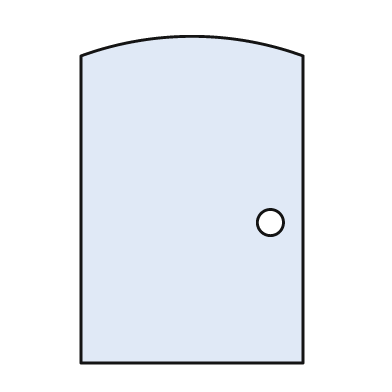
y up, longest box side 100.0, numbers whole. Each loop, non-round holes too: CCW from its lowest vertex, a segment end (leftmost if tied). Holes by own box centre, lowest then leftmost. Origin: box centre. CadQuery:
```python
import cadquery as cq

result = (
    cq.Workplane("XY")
    .moveTo(-34.0, -50.0)
    .lineTo(34.0, -50.0)
    .lineTo(34.0, 44.0)
    .threePointArc((0.0, 50.0), (-34.0, 44.0))
    .close()
    .moveTo(24.0, -7.0)
    .circle(4.0)
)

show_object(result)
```